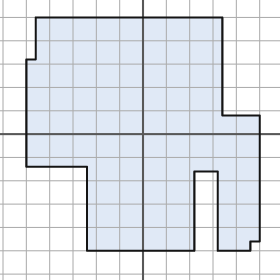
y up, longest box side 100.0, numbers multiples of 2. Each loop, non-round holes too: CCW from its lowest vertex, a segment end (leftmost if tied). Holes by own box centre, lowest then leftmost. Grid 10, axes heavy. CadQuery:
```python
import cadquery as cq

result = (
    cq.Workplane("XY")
    .moveTo(-24.0, -50.0)
    .lineTo(22.0, -50.0)
    .lineTo(22.0, -16.0)
    .lineTo(32.0, -16.0)
    .lineTo(32.0, -50.0)
    .lineTo(46.0, -50.0)
    .lineTo(46.0, -46.0)
    .lineTo(50.0, -46.0)
    .lineTo(50.0, 8.0)
    .lineTo(34.0, 8.0)
    .lineTo(34.0, 50.0)
    .lineTo(-46.0, 50.0)
    .lineTo(-46.0, 32.0)
    .lineTo(-50.0, 32.0)
    .lineTo(-50.0, -14.0)
    .lineTo(-24.0, -14.0)
    .close()
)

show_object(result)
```